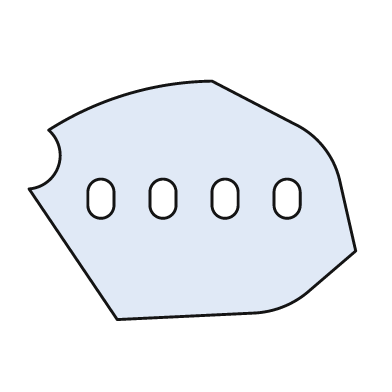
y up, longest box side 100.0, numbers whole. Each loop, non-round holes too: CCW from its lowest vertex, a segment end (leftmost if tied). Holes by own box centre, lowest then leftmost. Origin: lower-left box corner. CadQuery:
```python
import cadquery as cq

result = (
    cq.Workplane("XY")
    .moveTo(27.0, 0.0)
    .lineTo(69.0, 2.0)
    .threePointArc((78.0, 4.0), (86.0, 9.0))
    .lineTo(100.0, 21.0)
    .lineTo(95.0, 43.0)
    .threePointArc((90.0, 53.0), (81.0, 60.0))
    .lineTo(56.0, 73.0)
    .threePointArc((30.0, 69.0), (6.0, 58.0))
    .threePointArc((9.0, 47.0), (0.0, 40.0))
    .close()
    .moveTo(18.0, 35.0)
    .threePointArc((22.0, 31.0), (26.0, 35.0))
    .lineTo(26.0, 39.0)
    .threePointArc((22.0, 43.0), (18.0, 39.0))
    .close()
    .moveTo(37.0, 35.0)
    .threePointArc((41.0, 31.0), (45.0, 35.0))
    .lineTo(45.0, 39.0)
    .threePointArc((41.0, 43.0), (37.0, 39.0))
    .close()
    .moveTo(56.0, 35.0)
    .threePointArc((60.0, 31.0), (64.0, 35.0))
    .lineTo(64.0, 39.0)
    .threePointArc((60.0, 43.0), (56.0, 39.0))
    .close()
    .moveTo(75.0, 35.0)
    .threePointArc((79.0, 31.0), (83.0, 35.0))
    .lineTo(83.0, 39.0)
    .threePointArc((79.0, 43.0), (75.0, 39.0))
    .close()
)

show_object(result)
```